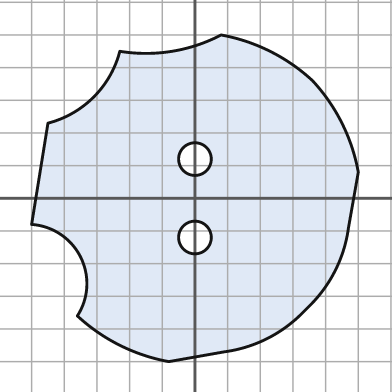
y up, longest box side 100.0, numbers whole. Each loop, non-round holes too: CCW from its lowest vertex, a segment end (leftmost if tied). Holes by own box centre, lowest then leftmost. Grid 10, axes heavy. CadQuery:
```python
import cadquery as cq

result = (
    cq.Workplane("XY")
    .moveTo(-8.0, -50.0)
    .lineTo(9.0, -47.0)
    .threePointArc((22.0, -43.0), (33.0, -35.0))
    .lineTo(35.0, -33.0)
    .threePointArc((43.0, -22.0), (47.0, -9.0))
    .lineTo(50.0, 8.0)
    .threePointArc((45.0, 23.0), (36.0, 36.0))
    .threePointArc((23.0, 45.0), (8.0, 50.0))
    .threePointArc((-7.0, 45.0), (-23.0, 45.0))
    .threePointArc((-31.0, 31.0), (-45.0, 23.0))
    .lineTo(-50.0, -8.0)
    .threePointArc((-35.0, -18.0), (-36.0, -36.0))
    .threePointArc((-23.0, -45.0), (-8.0, -50.0))
    .close()
    .moveTo(0.0, -12.0)
    .circle(5.0)
    .moveTo(0.0, 12.0)
    .circle(5.0)
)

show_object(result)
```